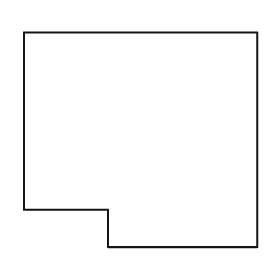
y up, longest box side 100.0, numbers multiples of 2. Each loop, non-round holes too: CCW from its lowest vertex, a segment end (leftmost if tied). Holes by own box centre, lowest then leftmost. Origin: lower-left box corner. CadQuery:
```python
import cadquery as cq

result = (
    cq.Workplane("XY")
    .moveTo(36.0, 0.0)
    .lineTo(100.0, 0.0)
    .lineTo(100.0, 92.0)
    .lineTo(0.0, 92.0)
    .lineTo(0.0, 16.0)
    .lineTo(36.0, 16.0)
    .close()
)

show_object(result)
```